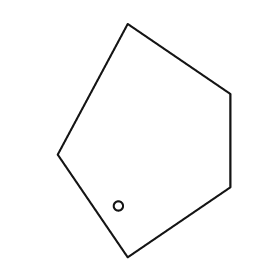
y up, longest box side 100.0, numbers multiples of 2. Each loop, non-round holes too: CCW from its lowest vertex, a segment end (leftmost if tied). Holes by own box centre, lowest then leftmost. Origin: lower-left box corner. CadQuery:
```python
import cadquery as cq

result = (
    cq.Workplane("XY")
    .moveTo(30.0, 0.0)
    .lineTo(74.0, 30.0)
    .lineTo(74.0, 70.0)
    .lineTo(30.0, 100.0)
    .lineTo(0.0, 44.0)
    .close()
    .moveTo(26.0, 22.0)
    .circle(2.0)
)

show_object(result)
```